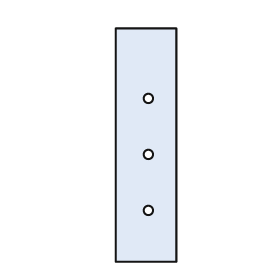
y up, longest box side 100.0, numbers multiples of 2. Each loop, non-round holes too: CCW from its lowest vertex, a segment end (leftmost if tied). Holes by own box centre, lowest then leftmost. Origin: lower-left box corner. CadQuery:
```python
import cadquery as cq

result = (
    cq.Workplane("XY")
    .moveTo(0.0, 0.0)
    .lineTo(26.0, 0.0)
    .lineTo(26.0, 100.0)
    .lineTo(0.0, 100.0)
    .close()
    .moveTo(14.0, 22.0)
    .circle(2.0)
    .moveTo(14.0, 46.0)
    .circle(2.0)
    .moveTo(14.0, 70.0)
    .circle(2.0)
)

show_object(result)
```